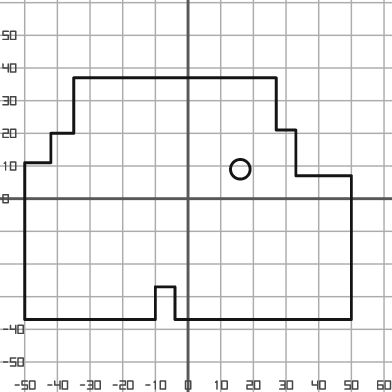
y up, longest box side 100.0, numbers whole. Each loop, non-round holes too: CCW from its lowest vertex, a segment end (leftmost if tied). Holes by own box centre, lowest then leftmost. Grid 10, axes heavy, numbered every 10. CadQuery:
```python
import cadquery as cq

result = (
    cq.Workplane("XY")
    .moveTo(-50.0, -37.0)
    .lineTo(-10.0, -37.0)
    .lineTo(-10.0, -27.0)
    .lineTo(-4.0, -27.0)
    .lineTo(-4.0, -37.0)
    .lineTo(50.0, -37.0)
    .lineTo(50.0, 7.0)
    .lineTo(33.0, 7.0)
    .lineTo(33.0, 21.0)
    .lineTo(27.0, 21.0)
    .lineTo(27.0, 37.0)
    .lineTo(-35.0, 37.0)
    .lineTo(-35.0, 20.0)
    .lineTo(-42.0, 20.0)
    .lineTo(-42.0, 11.0)
    .lineTo(-50.0, 11.0)
    .close()
    .moveTo(16.0, 9.0)
    .circle(3.0)
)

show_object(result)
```